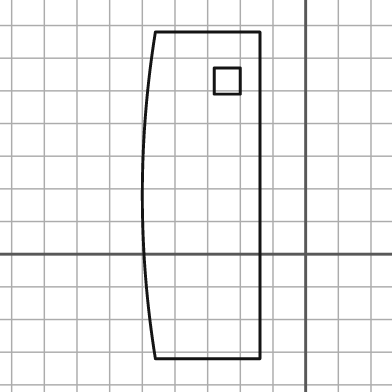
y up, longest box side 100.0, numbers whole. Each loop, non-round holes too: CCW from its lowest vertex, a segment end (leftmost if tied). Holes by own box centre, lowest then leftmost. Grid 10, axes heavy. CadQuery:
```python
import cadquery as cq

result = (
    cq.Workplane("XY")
    .moveTo(-46.0, -32.0)
    .lineTo(-14.0, -32.0)
    .lineTo(-14.0, 68.0)
    .lineTo(-46.0, 68.0)
    .threePointArc((-50.0, 18.0), (-46.0, -32.0))
    .close()
    .moveTo(-28.0, 49.0)
    .lineTo(-20.0, 49.0)
    .lineTo(-20.0, 57.0)
    .lineTo(-28.0, 57.0)
    .close()
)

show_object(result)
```